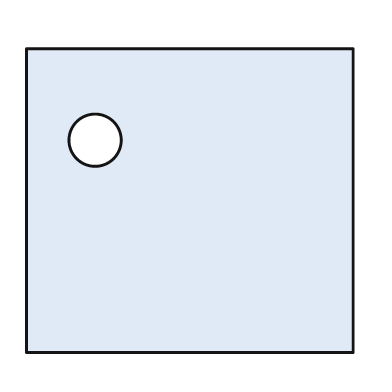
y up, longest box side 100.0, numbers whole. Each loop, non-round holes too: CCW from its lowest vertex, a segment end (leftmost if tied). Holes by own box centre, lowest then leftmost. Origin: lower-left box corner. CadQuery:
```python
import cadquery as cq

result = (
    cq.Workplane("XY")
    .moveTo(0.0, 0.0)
    .lineTo(100.0, 0.0)
    .lineTo(100.0, 93.0)
    .lineTo(0.0, 93.0)
    .close()
    .moveTo(21.0, 65.0)
    .circle(8.0)
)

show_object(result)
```